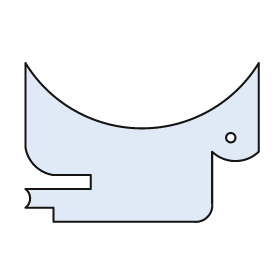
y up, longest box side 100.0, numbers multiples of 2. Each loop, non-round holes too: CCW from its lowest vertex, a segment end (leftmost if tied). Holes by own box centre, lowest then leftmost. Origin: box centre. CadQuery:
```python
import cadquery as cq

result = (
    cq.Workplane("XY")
    .moveTo(-38.0, -34.0)
    .lineTo(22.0, -34.0)
    .threePointArc((28.0, -32.0), (30.0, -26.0))
    .lineTo(30.0, -4.0)
    .threePointArc((40.0, -8.0), (50.0, -4.0))
    .lineTo(50.0, 34.0)
    .threePointArc((0.0, 6.0), (-50.0, 34.0))
    .lineTo(-50.0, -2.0)
    .threePointArc((-46.0, -10.0), (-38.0, -14.0))
    .lineTo(-22.0, -14.0)
    .lineTo(-22.0, -20.0)
    .lineTo(-50.0, -20.0)
    .threePointArc((-48.0, -24.0), (-50.0, -28.0))
    .lineTo(-38.0, -28.0)
    .close()
    .moveTo(38.0, 2.0)
    .circle(2.0)
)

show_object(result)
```